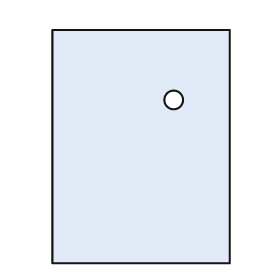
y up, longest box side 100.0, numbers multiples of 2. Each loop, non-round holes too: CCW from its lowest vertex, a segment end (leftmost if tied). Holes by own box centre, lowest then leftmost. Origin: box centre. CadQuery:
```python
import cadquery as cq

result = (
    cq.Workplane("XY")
    .moveTo(-38.0, -50.0)
    .lineTo(38.0, -50.0)
    .lineTo(38.0, 50.0)
    .lineTo(-38.0, 50.0)
    .close()
    .moveTo(14.0, 20.0)
    .circle(4.0)
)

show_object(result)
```